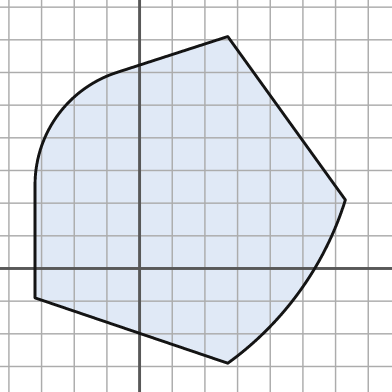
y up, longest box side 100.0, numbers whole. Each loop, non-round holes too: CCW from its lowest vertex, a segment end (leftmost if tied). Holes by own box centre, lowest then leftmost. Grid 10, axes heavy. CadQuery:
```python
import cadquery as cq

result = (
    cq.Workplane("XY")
    .moveTo(27.0, -29.0)
    .threePointArc((49.0, -7.0), (63.0, 21.0))
    .lineTo(27.0, 71.0)
    .lineTo(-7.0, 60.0)
    .threePointArc((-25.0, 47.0), (-32.0, 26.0))
    .lineTo(-32.0, -9.0)
    .close()
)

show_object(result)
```